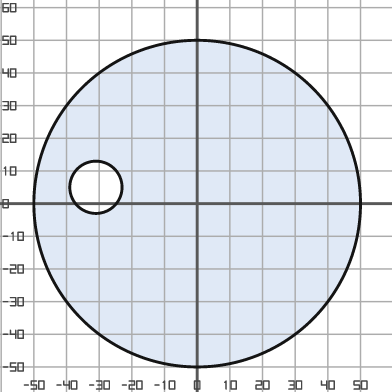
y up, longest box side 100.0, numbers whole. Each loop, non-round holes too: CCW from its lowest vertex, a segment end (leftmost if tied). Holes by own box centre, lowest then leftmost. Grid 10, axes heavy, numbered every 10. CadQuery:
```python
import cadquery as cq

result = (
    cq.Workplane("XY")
    .moveTo(0.0, 0.0)
    .circle(50.0)
    .moveTo(-31.0, 5.0)
    .circle(8.0)
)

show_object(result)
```